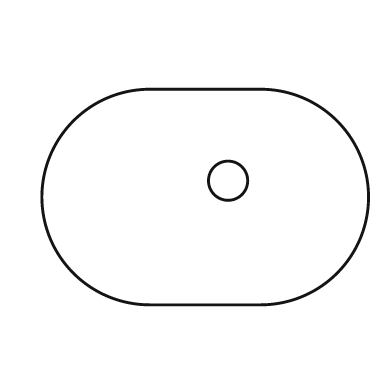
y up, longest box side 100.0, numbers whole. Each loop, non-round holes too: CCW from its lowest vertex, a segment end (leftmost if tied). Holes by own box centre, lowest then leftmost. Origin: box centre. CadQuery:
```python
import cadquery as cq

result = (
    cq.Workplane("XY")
    .moveTo(-17.0, -33.0)
    .lineTo(17.0, -33.0)
    .threePointArc((50.0, 0.0), (17.0, 33.0))
    .lineTo(-17.0, 33.0)
    .threePointArc((-50.0, 0.0), (-17.0, -33.0))
    .close()
    .moveTo(7.0, 5.0)
    .circle(6.0)
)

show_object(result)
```